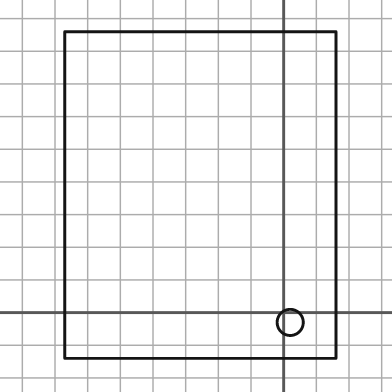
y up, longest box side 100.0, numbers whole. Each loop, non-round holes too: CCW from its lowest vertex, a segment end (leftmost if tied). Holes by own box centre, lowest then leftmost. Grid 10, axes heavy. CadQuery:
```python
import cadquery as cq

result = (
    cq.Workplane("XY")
    .moveTo(-67.0, -14.0)
    .lineTo(16.0, -14.0)
    .lineTo(16.0, 86.0)
    .lineTo(-67.0, 86.0)
    .close()
    .moveTo(2.0, -3.0)
    .circle(4.0)
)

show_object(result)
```